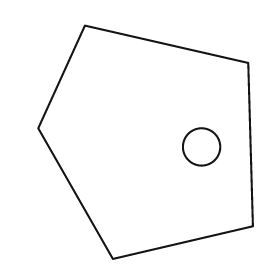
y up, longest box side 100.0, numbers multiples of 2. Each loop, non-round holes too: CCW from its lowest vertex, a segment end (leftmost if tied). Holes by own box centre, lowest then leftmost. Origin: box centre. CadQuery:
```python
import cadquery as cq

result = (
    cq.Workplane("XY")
    .moveTo(-14.0, -50.0)
    .lineTo(46.0, -36.0)
    .lineTo(44.0, 34.0)
    .lineTo(-26.0, 50.0)
    .lineTo(-46.0, 6.0)
    .close()
    .moveTo(24.0, -2.0)
    .circle(8.0)
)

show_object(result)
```